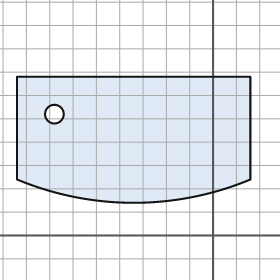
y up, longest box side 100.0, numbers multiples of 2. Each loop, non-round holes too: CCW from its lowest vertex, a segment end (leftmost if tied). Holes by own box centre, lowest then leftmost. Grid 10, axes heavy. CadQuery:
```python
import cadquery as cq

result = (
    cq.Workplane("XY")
    .moveTo(-84.0, 24.0)
    .threePointArc((-34.0, 14.0), (16.0, 24.0))
    .lineTo(16.0, 68.0)
    .lineTo(-84.0, 68.0)
    .close()
    .moveTo(-68.0, 52.0)
    .circle(4.0)
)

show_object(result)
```